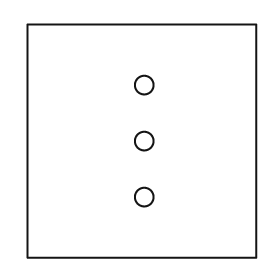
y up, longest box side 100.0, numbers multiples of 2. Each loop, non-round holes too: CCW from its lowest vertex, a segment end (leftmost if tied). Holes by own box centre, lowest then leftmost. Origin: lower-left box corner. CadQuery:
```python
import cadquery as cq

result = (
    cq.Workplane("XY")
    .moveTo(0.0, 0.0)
    .lineTo(98.0, 0.0)
    .lineTo(98.0, 100.0)
    .lineTo(0.0, 100.0)
    .close()
    .moveTo(50.0, 26.0)
    .circle(4.0)
    .moveTo(50.0, 50.0)
    .circle(4.0)
    .moveTo(50.0, 74.0)
    .circle(4.0)
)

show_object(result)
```